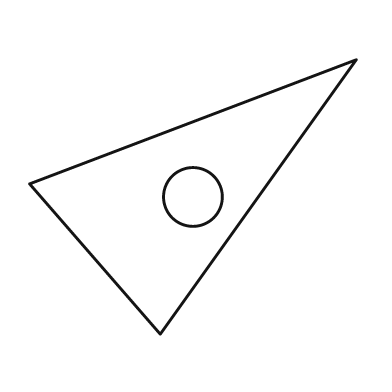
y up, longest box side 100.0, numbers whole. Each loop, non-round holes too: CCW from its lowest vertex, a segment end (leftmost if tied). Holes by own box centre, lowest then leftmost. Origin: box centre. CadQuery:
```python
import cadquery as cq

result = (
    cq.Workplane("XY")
    .moveTo(-10.0, -42.0)
    .lineTo(50.0, 42.0)
    .lineTo(-50.0, 4.0)
    .close()
    .moveTo(0.0, 0.0)
    .circle(9.0)
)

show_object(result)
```